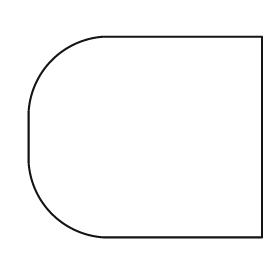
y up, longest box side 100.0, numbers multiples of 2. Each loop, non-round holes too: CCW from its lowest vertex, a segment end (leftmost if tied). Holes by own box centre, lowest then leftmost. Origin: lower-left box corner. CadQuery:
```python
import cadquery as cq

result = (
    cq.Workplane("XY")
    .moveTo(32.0, 0.0)
    .lineTo(100.0, 0.0)
    .lineTo(100.0, 86.0)
    .lineTo(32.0, 86.0)
    .threePointArc((10.0, 76.0), (0.0, 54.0))
    .lineTo(0.0, 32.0)
    .threePointArc((10.0, 10.0), (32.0, 0.0))
    .close()
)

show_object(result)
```